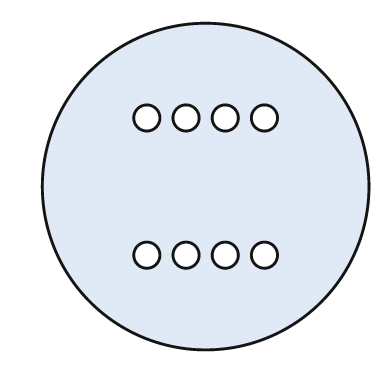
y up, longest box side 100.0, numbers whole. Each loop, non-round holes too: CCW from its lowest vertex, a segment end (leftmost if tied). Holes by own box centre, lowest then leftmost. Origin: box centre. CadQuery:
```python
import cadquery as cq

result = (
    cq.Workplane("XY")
    .moveTo(0.0, 0.0)
    .circle(50.0)
    .moveTo(-18.0, -21.0)
    .circle(4.0)
    .moveTo(-6.0, -21.0)
    .circle(4.0)
    .moveTo(6.0, -21.0)
    .circle(4.0)
    .moveTo(18.0, -21.0)
    .circle(4.0)
    .moveTo(-18.0, 21.0)
    .circle(4.0)
    .moveTo(-6.0, 21.0)
    .circle(4.0)
    .moveTo(6.0, 21.0)
    .circle(4.0)
    .moveTo(18.0, 21.0)
    .circle(4.0)
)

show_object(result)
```